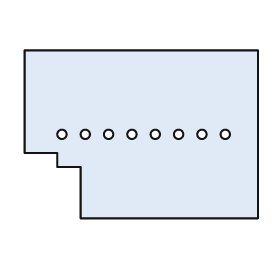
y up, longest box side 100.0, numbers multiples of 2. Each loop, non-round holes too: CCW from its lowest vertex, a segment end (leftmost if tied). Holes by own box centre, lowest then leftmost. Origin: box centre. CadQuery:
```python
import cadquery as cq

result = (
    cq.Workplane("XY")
    .moveTo(-26.0, -36.0)
    .lineTo(50.0, -36.0)
    .lineTo(50.0, 36.0)
    .lineTo(-50.0, 36.0)
    .lineTo(-50.0, -8.0)
    .lineTo(-36.0, -8.0)
    .lineTo(-36.0, -14.0)
    .lineTo(-26.0, -14.0)
    .close()
    .moveTo(-34.0, 0.0)
    .circle(2.0)
    .moveTo(-24.0, 0.0)
    .circle(2.0)
    .moveTo(-14.0, 0.0)
    .circle(2.0)
    .moveTo(-4.0, 0.0)
    .circle(2.0)
    .moveTo(6.0, 0.0)
    .circle(2.0)
    .moveTo(16.0, 0.0)
    .circle(2.0)
    .moveTo(26.0, 0.0)
    .circle(2.0)
    .moveTo(36.0, 0.0)
    .circle(2.0)
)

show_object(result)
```